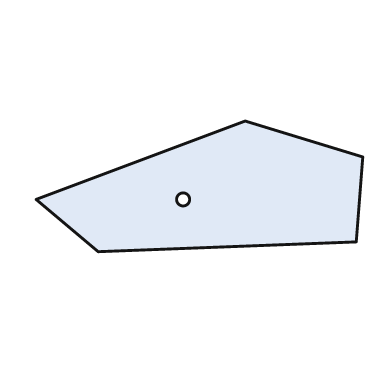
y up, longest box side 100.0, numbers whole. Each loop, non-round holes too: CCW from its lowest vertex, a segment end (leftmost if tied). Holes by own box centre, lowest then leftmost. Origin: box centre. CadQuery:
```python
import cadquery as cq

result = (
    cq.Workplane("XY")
    .moveTo(-31.0, -20.0)
    .lineTo(48.0, -17.0)
    .lineTo(50.0, 9.0)
    .lineTo(14.0, 20.0)
    .lineTo(-50.0, -4.0)
    .close()
    .moveTo(-5.0, -4.0)
    .circle(2.0)
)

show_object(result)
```